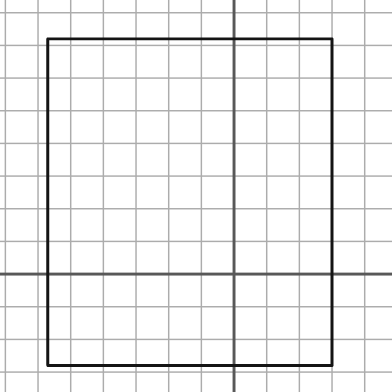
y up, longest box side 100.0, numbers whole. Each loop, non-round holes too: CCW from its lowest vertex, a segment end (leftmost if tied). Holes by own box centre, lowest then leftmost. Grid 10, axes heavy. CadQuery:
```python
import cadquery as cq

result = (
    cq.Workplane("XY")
    .moveTo(-57.0, -28.0)
    .lineTo(30.0, -28.0)
    .lineTo(30.0, 72.0)
    .lineTo(-57.0, 72.0)
    .close()
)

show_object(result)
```